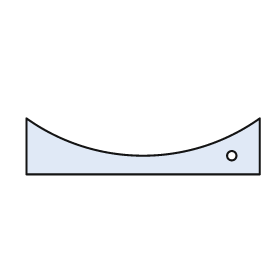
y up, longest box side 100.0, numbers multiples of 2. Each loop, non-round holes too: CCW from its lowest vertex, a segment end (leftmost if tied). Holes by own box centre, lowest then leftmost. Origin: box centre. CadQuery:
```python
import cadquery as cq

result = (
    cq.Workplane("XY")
    .moveTo(-50.0, -12.0)
    .lineTo(50.0, -12.0)
    .lineTo(50.0, 12.0)
    .threePointArc((0.0, -4.0), (-50.0, 12.0))
    .close()
    .moveTo(38.0, -4.0)
    .circle(2.0)
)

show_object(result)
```